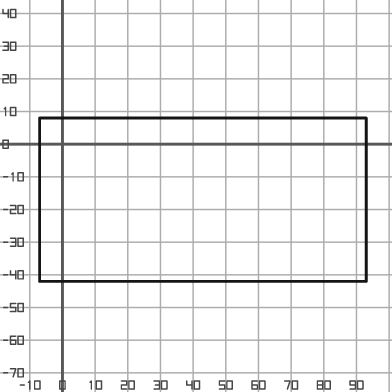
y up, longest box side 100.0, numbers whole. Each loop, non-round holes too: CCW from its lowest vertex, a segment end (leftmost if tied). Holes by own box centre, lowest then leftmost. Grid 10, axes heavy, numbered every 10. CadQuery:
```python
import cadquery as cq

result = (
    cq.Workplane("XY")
    .moveTo(-7.0, -42.0)
    .lineTo(93.0, -42.0)
    .lineTo(93.0, 8.0)
    .lineTo(-7.0, 8.0)
    .close()
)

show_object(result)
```